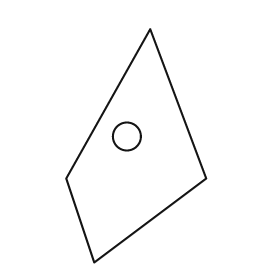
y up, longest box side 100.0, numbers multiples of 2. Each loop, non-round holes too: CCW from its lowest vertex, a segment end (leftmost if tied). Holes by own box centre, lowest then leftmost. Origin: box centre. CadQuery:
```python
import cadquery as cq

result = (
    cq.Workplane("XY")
    .moveTo(-18.0, -50.0)
    .lineTo(30.0, -14.0)
    .lineTo(6.0, 50.0)
    .lineTo(-30.0, -14.0)
    .close()
    .moveTo(-4.0, 4.0)
    .circle(6.0)
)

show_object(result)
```